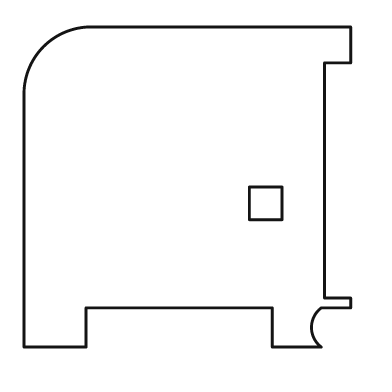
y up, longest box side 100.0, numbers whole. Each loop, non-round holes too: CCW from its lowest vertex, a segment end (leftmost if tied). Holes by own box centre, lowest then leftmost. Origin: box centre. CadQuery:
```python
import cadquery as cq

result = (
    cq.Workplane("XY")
    .moveTo(-50.0, -49.0)
    .lineTo(-31.0, -49.0)
    .lineTo(-31.0, -37.0)
    .lineTo(26.0, -37.0)
    .lineTo(26.0, -49.0)
    .lineTo(41.0, -49.0)
    .threePointArc((38.0, -43.0), (41.0, -37.0))
    .lineTo(50.0, -37.0)
    .lineTo(50.0, -34.0)
    .lineTo(42.0, -34.0)
    .lineTo(42.0, 38.0)
    .lineTo(50.0, 38.0)
    .lineTo(50.0, 49.0)
    .lineTo(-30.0, 49.0)
    .threePointArc((-44.0, 43.0), (-50.0, 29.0))
    .close()
    .moveTo(19.0, -10.0)
    .lineTo(29.0, -10.0)
    .lineTo(29.0, 0.0)
    .lineTo(19.0, 0.0)
    .close()
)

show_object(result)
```